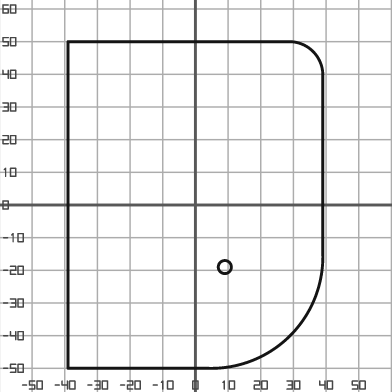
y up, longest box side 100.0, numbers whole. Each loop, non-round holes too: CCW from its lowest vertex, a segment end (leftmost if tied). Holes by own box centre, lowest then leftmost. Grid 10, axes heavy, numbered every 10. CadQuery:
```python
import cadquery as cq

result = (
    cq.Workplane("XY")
    .moveTo(-39.0, -50.0)
    .lineTo(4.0, -50.0)
    .threePointArc((29.0, -40.0), (39.0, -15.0))
    .lineTo(39.0, 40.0)
    .threePointArc((36.0, 47.0), (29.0, 50.0))
    .lineTo(-39.0, 50.0)
    .close()
    .moveTo(9.0, -19.0)
    .circle(2.0)
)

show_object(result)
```